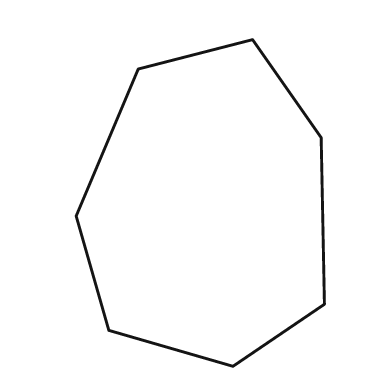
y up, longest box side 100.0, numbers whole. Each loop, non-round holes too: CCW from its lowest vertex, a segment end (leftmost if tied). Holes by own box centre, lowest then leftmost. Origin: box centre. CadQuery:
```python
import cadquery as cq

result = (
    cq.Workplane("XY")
    .moveTo(10.0, -50.0)
    .lineTo(38.0, -31.0)
    .lineTo(37.0, 20.0)
    .lineTo(16.0, 50.0)
    .lineTo(-19.0, 41.0)
    .lineTo(-38.0, -4.0)
    .lineTo(-28.0, -39.0)
    .close()
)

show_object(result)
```